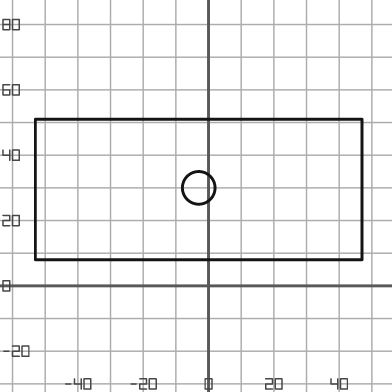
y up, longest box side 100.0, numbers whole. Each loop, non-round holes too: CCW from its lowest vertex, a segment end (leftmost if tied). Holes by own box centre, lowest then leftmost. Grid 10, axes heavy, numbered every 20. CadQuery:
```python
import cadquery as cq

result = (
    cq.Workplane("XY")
    .moveTo(-53.0, 8.0)
    .lineTo(47.0, 8.0)
    .lineTo(47.0, 51.0)
    .lineTo(-53.0, 51.0)
    .close()
    .moveTo(-3.0, 30.0)
    .circle(5.0)
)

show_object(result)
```